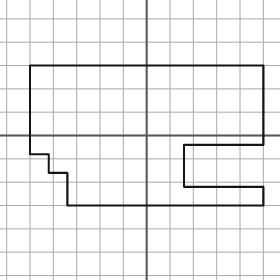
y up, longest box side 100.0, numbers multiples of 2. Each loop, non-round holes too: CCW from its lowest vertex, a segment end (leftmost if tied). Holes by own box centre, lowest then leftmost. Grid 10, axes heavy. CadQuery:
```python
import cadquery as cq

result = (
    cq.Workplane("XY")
    .moveTo(-34.0, -30.0)
    .lineTo(50.0, -30.0)
    .lineTo(50.0, -22.0)
    .lineTo(16.0, -22.0)
    .lineTo(16.0, -4.0)
    .lineTo(50.0, -4.0)
    .lineTo(50.0, 30.0)
    .lineTo(-50.0, 30.0)
    .lineTo(-50.0, -8.0)
    .lineTo(-42.0, -8.0)
    .lineTo(-42.0, -16.0)
    .lineTo(-34.0, -16.0)
    .close()
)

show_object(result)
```